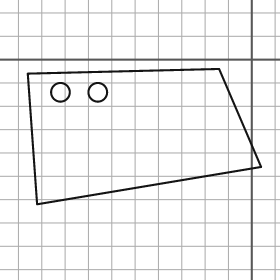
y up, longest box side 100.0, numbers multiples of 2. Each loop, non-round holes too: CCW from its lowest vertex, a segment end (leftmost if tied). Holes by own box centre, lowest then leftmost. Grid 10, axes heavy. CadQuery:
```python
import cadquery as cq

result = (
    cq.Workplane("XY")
    .moveTo(-92.0, -62.0)
    .lineTo(4.0, -46.0)
    .lineTo(-14.0, -4.0)
    .lineTo(-96.0, -6.0)
    .close()
    .moveTo(-82.0, -14.0)
    .circle(4.0)
    .moveTo(-66.0, -14.0)
    .circle(4.0)
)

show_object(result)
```